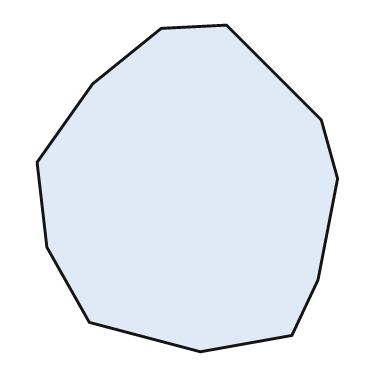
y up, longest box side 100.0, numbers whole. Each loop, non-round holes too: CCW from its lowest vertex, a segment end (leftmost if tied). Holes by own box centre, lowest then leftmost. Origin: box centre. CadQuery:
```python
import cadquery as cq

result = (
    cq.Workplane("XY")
    .moveTo(4.0, -50.0)
    .lineTo(32.0, -45.0)
    .lineTo(40.0, -28.0)
    .lineTo(46.0, 3.0)
    .lineTo(41.0, 21.0)
    .lineTo(12.0, 50.0)
    .lineTo(-8.0, 49.0)
    .lineTo(-29.0, 32.0)
    .lineTo(-46.0, 8.0)
    .lineTo(-43.0, -18.0)
    .lineTo(-30.0, -41.0)
    .close()
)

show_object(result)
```